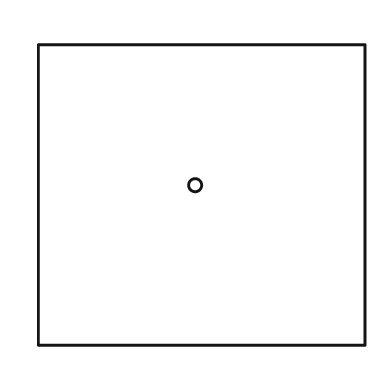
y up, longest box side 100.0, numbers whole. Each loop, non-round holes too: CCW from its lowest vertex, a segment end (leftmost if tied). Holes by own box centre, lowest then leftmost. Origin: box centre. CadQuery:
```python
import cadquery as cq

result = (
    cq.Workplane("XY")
    .moveTo(-50.0, -46.0)
    .lineTo(50.0, -46.0)
    .lineTo(50.0, 46.0)
    .lineTo(-50.0, 46.0)
    .close()
    .moveTo(-2.0, 3.0)
    .circle(2.0)
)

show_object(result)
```